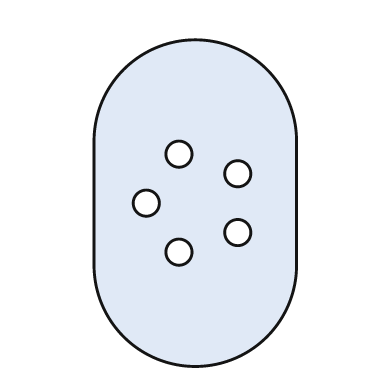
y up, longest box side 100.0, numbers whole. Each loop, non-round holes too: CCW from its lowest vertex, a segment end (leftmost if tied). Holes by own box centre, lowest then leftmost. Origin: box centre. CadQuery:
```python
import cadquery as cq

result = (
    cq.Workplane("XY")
    .moveTo(-31.0, -19.0)
    .threePointArc((0.0, -50.0), (31.0, -19.0))
    .lineTo(31.0, 19.0)
    .threePointArc((0.0, 50.0), (-31.0, 19.0))
    .close()
    .moveTo(-5.0, -15.0)
    .circle(4.0)
    .moveTo(13.0, -9.0)
    .circle(4.0)
    .moveTo(-15.0, 0.0)
    .circle(4.0)
    .moveTo(13.0, 9.0)
    .circle(4.0)
    .moveTo(-5.0, 15.0)
    .circle(4.0)
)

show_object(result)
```